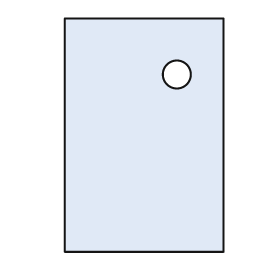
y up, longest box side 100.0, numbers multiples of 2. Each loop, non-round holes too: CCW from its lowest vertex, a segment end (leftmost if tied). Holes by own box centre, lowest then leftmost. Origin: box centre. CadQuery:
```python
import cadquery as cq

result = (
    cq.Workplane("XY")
    .moveTo(-34.0, -50.0)
    .lineTo(34.0, -50.0)
    .lineTo(34.0, 50.0)
    .lineTo(-34.0, 50.0)
    .close()
    .moveTo(14.0, 26.0)
    .circle(6.0)
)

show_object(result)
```